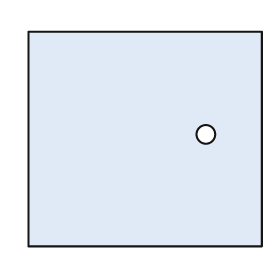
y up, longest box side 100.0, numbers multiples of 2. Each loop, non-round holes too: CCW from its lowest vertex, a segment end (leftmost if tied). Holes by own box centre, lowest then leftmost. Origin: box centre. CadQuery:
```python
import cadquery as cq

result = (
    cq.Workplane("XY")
    .moveTo(-50.0, -46.0)
    .lineTo(50.0, -46.0)
    .lineTo(50.0, 46.0)
    .lineTo(-50.0, 46.0)
    .close()
    .moveTo(26.0, 2.0)
    .circle(4.0)
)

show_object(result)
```